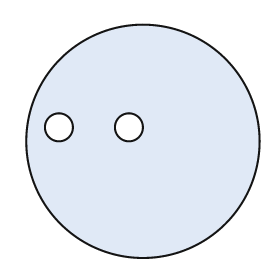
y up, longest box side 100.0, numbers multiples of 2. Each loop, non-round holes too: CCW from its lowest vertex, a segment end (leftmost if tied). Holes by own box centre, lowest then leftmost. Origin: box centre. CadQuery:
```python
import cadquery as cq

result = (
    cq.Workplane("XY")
    .moveTo(0.0, 0.0)
    .circle(50.0)
    .moveTo(-36.0, 6.0)
    .circle(6.0)
    .moveTo(-6.0, 6.0)
    .circle(6.0)
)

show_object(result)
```